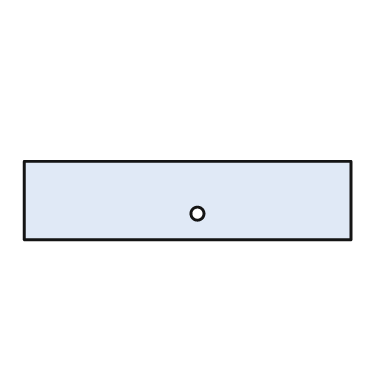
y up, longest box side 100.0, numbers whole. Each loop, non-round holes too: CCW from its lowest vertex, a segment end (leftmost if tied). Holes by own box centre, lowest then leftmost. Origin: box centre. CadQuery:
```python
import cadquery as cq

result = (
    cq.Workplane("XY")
    .moveTo(-50.0, -12.0)
    .lineTo(50.0, -12.0)
    .lineTo(50.0, 12.0)
    .lineTo(-50.0, 12.0)
    .close()
    .moveTo(3.0, -4.0)
    .circle(2.0)
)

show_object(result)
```